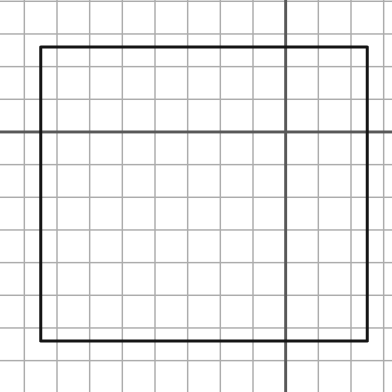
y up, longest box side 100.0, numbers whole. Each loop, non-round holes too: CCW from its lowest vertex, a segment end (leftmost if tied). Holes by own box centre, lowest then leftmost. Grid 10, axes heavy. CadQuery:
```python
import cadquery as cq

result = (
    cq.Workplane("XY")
    .moveTo(-75.0, -64.0)
    .lineTo(25.0, -64.0)
    .lineTo(25.0, 26.0)
    .lineTo(-75.0, 26.0)
    .close()
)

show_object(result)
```